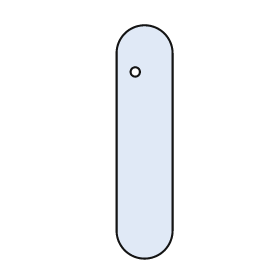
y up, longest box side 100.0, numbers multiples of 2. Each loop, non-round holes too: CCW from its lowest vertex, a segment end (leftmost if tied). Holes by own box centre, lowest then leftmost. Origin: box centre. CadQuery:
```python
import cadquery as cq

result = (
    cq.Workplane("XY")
    .moveTo(-12.0, -38.0)
    .threePointArc((0.0, -50.0), (12.0, -38.0))
    .lineTo(12.0, 38.0)
    .threePointArc((0.0, 50.0), (-12.0, 38.0))
    .close()
    .moveTo(-4.0, 30.0)
    .circle(2.0)
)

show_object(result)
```